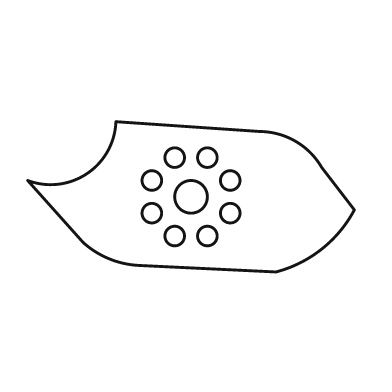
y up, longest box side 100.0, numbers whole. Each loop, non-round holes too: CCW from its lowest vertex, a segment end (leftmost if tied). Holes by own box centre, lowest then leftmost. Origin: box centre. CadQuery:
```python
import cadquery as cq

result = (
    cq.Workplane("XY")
    .moveTo(26.0, -23.0)
    .threePointArc((40.0, -16.0), (50.0, -4.0))
    .lineTo(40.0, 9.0)
    .threePointArc((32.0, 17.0), (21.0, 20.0))
    .lineTo(-23.0, 23.0)
    .threePointArc((-32.0, 7.0), (-50.0, 5.0))
    .lineTo(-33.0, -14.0)
    .threePointArc((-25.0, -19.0), (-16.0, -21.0))
    .close()
    .moveTo(-5.0, -12.0)
    .circle(3.0)
    .moveTo(5.0, -12.0)
    .circle(3.0)
    .moveTo(-12.0, -5.0)
    .circle(3.0)
    .moveTo(12.0, -5.0)
    .circle(3.0)
    .moveTo(0.0, 0.0)
    .circle(5.0)
    .moveTo(-12.0, 5.0)
    .circle(3.0)
    .moveTo(12.0, 5.0)
    .circle(3.0)
    .moveTo(-5.0, 12.0)
    .circle(3.0)
    .moveTo(5.0, 12.0)
    .circle(3.0)
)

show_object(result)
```